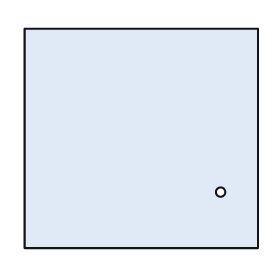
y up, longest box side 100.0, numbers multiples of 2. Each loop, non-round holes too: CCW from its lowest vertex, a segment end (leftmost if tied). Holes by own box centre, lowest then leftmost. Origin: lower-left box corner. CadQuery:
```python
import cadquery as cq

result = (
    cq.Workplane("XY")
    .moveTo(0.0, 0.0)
    .lineTo(100.0, 0.0)
    .lineTo(100.0, 94.0)
    .lineTo(0.0, 94.0)
    .close()
    .moveTo(84.0, 24.0)
    .circle(2.0)
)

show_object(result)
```